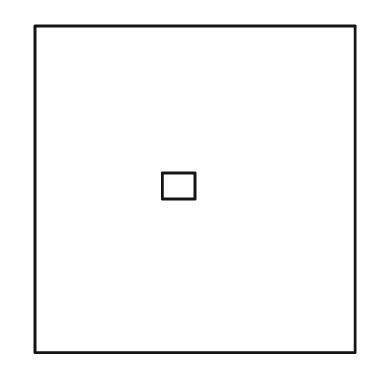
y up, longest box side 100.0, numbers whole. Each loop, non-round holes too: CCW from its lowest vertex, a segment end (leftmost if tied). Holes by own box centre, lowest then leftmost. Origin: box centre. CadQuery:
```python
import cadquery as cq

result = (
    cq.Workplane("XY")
    .moveTo(-49.0, -50.0)
    .lineTo(49.0, -50.0)
    .lineTo(49.0, 50.0)
    .lineTo(-49.0, 50.0)
    .close()
    .moveTo(-10.0, -3.0)
    .lineTo(0.0, -3.0)
    .lineTo(0.0, 5.0)
    .lineTo(-10.0, 5.0)
    .close()
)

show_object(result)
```